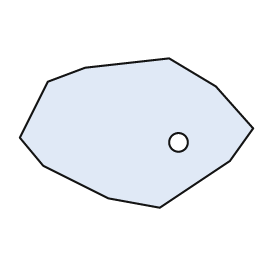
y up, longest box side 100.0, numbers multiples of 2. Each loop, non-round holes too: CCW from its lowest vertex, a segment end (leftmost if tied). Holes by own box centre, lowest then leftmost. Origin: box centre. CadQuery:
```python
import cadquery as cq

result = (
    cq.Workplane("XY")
    .moveTo(10.0, -32.0)
    .lineTo(40.0, -12.0)
    .lineTo(50.0, 2.0)
    .lineTo(34.0, 20.0)
    .lineTo(14.0, 32.0)
    .lineTo(-22.0, 28.0)
    .lineTo(-38.0, 22.0)
    .lineTo(-50.0, -2.0)
    .lineTo(-40.0, -14.0)
    .lineTo(-12.0, -28.0)
    .close()
    .moveTo(18.0, -4.0)
    .circle(4.0)
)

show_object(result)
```